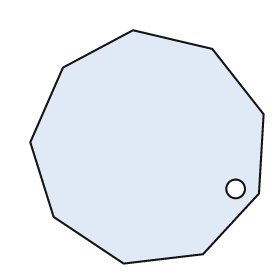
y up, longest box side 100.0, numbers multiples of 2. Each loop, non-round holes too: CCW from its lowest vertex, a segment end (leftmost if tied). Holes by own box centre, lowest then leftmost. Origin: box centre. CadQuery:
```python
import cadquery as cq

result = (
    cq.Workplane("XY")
    .moveTo(-10.0, -50.0)
    .lineTo(24.0, -46.0)
    .lineTo(48.0, -20.0)
    .lineTo(50.0, 14.0)
    .lineTo(28.0, 42.0)
    .lineTo(-6.0, 50.0)
    .lineTo(-36.0, 34.0)
    .lineTo(-50.0, 2.0)
    .lineTo(-40.0, -30.0)
    .close()
    .moveTo(38.0, -18.0)
    .circle(4.0)
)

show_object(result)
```